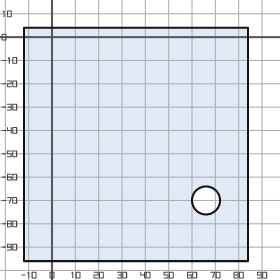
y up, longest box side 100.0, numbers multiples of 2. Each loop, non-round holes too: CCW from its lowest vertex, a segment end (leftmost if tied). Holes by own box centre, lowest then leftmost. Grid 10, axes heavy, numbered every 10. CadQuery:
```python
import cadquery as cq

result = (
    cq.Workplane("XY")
    .moveTo(-12.0, -96.0)
    .lineTo(84.0, -96.0)
    .lineTo(84.0, 4.0)
    .lineTo(-12.0, 4.0)
    .close()
    .moveTo(66.0, -70.0)
    .circle(6.0)
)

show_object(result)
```